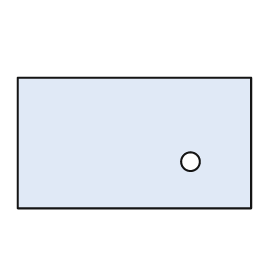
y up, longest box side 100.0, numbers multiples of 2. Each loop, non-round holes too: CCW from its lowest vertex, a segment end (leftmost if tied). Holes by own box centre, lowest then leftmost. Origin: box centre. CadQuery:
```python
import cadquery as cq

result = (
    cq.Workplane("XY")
    .moveTo(-50.0, -28.0)
    .lineTo(50.0, -28.0)
    .lineTo(50.0, 28.0)
    .lineTo(-50.0, 28.0)
    .close()
    .moveTo(24.0, -8.0)
    .circle(4.0)
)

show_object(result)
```